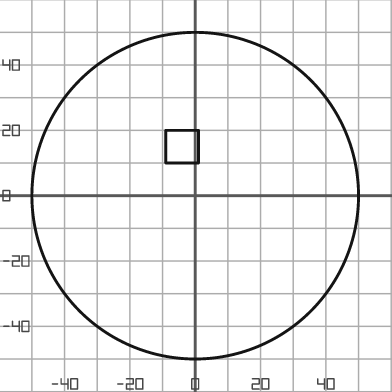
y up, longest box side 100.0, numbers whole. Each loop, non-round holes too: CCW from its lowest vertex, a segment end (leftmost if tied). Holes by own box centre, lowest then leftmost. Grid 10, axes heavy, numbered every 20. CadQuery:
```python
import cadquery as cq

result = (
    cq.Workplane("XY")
    .moveTo(0.0, 0.0)
    .circle(50.0)
    .moveTo(-9.0, 10.0)
    .lineTo(1.0, 10.0)
    .lineTo(1.0, 20.0)
    .lineTo(-9.0, 20.0)
    .close()
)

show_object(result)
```